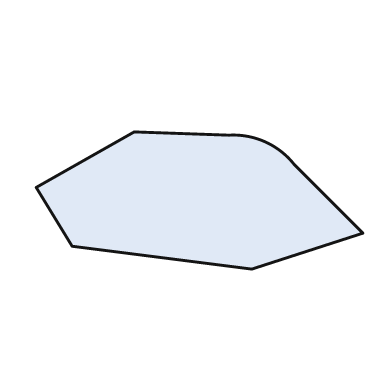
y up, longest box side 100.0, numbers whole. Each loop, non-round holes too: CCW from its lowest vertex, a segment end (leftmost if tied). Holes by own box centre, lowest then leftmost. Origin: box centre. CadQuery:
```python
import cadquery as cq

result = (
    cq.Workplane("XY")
    .moveTo(16.0, -21.0)
    .lineTo(50.0, -10.0)
    .lineTo(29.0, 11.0)
    .threePointArc((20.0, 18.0), (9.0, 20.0))
    .lineTo(-20.0, 21.0)
    .lineTo(-50.0, 4.0)
    .lineTo(-39.0, -14.0)
    .close()
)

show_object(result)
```